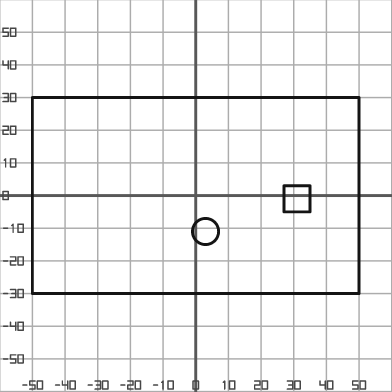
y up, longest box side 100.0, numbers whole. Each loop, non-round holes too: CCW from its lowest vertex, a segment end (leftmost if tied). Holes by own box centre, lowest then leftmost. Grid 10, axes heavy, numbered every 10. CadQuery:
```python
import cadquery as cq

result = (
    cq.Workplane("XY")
    .moveTo(-50.0, -30.0)
    .lineTo(50.0, -30.0)
    .lineTo(50.0, 30.0)
    .lineTo(-50.0, 30.0)
    .close()
    .moveTo(3.0, -11.0)
    .circle(4.0)
    .moveTo(27.0, -5.0)
    .lineTo(35.0, -5.0)
    .lineTo(35.0, 3.0)
    .lineTo(27.0, 3.0)
    .close()
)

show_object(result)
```